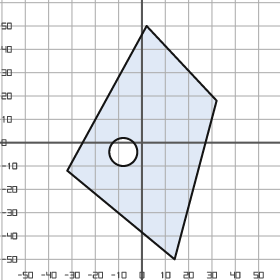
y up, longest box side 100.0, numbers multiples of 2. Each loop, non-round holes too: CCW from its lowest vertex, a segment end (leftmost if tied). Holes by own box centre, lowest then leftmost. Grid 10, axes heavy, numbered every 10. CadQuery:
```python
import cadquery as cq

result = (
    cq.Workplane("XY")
    .moveTo(14.0, -50.0)
    .lineTo(32.0, 18.0)
    .lineTo(2.0, 50.0)
    .lineTo(-32.0, -12.0)
    .close()
    .moveTo(-8.0, -4.0)
    .circle(6.0)
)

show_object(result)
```